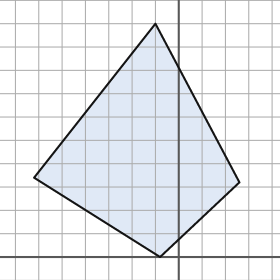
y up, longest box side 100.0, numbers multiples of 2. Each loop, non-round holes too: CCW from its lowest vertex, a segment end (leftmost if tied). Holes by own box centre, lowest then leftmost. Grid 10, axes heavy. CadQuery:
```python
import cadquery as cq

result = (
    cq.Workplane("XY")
    .moveTo(-8.0, 0.0)
    .lineTo(26.0, 32.0)
    .lineTo(-10.0, 100.0)
    .lineTo(-62.0, 34.0)
    .close()
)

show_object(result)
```